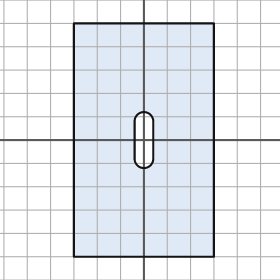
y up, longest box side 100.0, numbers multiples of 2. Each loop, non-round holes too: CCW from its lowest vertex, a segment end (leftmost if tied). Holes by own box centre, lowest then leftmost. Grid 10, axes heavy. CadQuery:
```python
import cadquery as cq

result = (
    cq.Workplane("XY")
    .moveTo(-30.0, -50.0)
    .lineTo(30.0, -50.0)
    .lineTo(30.0, 50.0)
    .lineTo(-30.0, 50.0)
    .close()
    .moveTo(-4.0, -8.0)
    .threePointArc((0.0, -12.0), (4.0, -8.0))
    .lineTo(4.0, 8.0)
    .threePointArc((0.0, 12.0), (-4.0, 8.0))
    .close()
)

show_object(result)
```